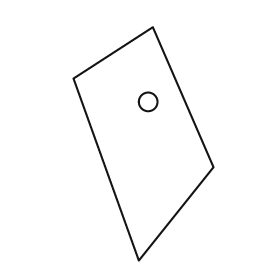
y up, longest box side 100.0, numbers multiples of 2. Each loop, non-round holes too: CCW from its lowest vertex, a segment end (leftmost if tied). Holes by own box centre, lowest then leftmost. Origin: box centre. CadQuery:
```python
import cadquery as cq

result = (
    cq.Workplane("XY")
    .moveTo(-2.0, -50.0)
    .lineTo(30.0, -10.0)
    .lineTo(4.0, 50.0)
    .lineTo(-30.0, 28.0)
    .close()
    .moveTo(2.0, 18.0)
    .circle(4.0)
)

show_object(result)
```